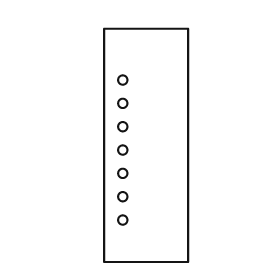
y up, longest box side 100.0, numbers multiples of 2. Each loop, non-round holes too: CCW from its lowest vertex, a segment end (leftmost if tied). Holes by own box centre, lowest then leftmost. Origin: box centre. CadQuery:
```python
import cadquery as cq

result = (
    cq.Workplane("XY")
    .moveTo(-18.0, -50.0)
    .lineTo(18.0, -50.0)
    .lineTo(18.0, 50.0)
    .lineTo(-18.0, 50.0)
    .close()
    .moveTo(-10.0, -32.0)
    .circle(2.0)
    .moveTo(-10.0, -22.0)
    .circle(2.0)
    .moveTo(-10.0, -12.0)
    .circle(2.0)
    .moveTo(-10.0, -2.0)
    .circle(2.0)
    .moveTo(-10.0, 8.0)
    .circle(2.0)
    .moveTo(-10.0, 18.0)
    .circle(2.0)
    .moveTo(-10.0, 28.0)
    .circle(2.0)
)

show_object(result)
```